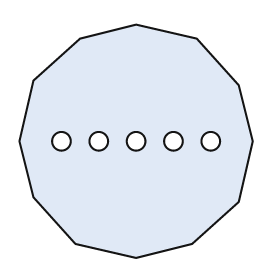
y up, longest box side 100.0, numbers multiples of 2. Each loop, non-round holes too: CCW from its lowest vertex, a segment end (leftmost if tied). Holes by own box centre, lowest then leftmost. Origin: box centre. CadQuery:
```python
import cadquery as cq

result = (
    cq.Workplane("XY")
    .moveTo(0.0, -50.0)
    .lineTo(24.0, -44.0)
    .lineTo(44.0, -26.0)
    .lineTo(50.0, 0.0)
    .lineTo(44.0, 24.0)
    .lineTo(26.0, 44.0)
    .lineTo(0.0, 50.0)
    .lineTo(-24.0, 44.0)
    .lineTo(-44.0, 26.0)
    .lineTo(-50.0, 0.0)
    .lineTo(-44.0, -24.0)
    .lineTo(-26.0, -44.0)
    .close()
    .moveTo(-32.0, 0.0)
    .circle(4.0)
    .moveTo(-16.0, 0.0)
    .circle(4.0)
    .moveTo(0.0, 0.0)
    .circle(4.0)
    .moveTo(16.0, 0.0)
    .circle(4.0)
    .moveTo(32.0, 0.0)
    .circle(4.0)
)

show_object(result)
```